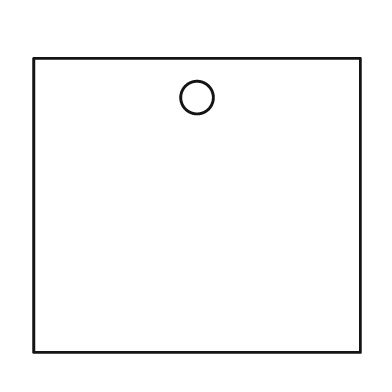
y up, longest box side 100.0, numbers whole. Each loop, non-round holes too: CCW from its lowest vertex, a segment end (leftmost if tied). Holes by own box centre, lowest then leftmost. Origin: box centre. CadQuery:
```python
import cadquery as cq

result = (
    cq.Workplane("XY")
    .moveTo(-50.0, -45.0)
    .lineTo(50.0, -45.0)
    .lineTo(50.0, 45.0)
    .lineTo(-50.0, 45.0)
    .close()
    .moveTo(0.0, 33.0)
    .circle(5.0)
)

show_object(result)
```